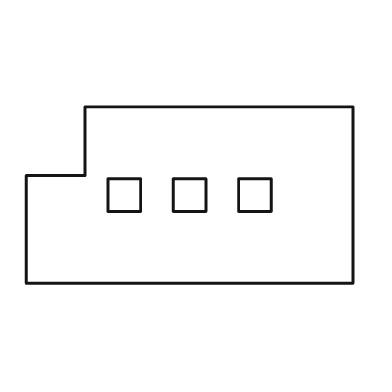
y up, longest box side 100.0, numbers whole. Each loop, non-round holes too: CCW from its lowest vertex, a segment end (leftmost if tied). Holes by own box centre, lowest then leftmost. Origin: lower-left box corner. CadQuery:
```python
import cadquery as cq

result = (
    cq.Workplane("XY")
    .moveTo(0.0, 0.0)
    .lineTo(100.0, 0.0)
    .lineTo(100.0, 54.0)
    .lineTo(18.0, 54.0)
    .lineTo(18.0, 33.0)
    .lineTo(0.0, 33.0)
    .close()
    .moveTo(25.0, 22.0)
    .lineTo(35.0, 22.0)
    .lineTo(35.0, 32.0)
    .lineTo(25.0, 32.0)
    .close()
    .moveTo(45.0, 22.0)
    .lineTo(55.0, 22.0)
    .lineTo(55.0, 32.0)
    .lineTo(45.0, 32.0)
    .close()
    .moveTo(65.0, 22.0)
    .lineTo(75.0, 22.0)
    .lineTo(75.0, 32.0)
    .lineTo(65.0, 32.0)
    .close()
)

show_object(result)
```